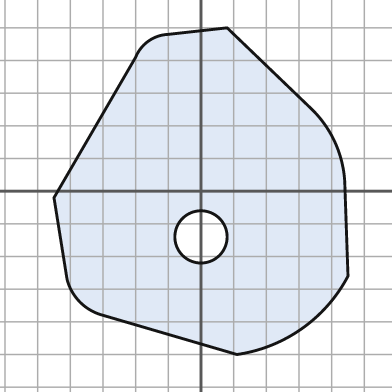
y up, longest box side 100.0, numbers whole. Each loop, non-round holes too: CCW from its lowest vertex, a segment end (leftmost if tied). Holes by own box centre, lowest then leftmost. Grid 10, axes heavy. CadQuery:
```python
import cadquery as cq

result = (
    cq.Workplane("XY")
    .moveTo(11.0, -50.0)
    .threePointArc((31.0, -42.0), (45.0, -26.0))
    .lineTo(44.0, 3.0)
    .threePointArc((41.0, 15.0), (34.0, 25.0))
    .lineTo(8.0, 50.0)
    .lineTo(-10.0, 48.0)
    .threePointArc((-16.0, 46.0), (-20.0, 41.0))
    .lineTo(-45.0, -2.0)
    .lineTo(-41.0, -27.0)
    .threePointArc((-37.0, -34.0), (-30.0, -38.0))
    .close()
    .moveTo(0.0, -14.0)
    .circle(8.0)
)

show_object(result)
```